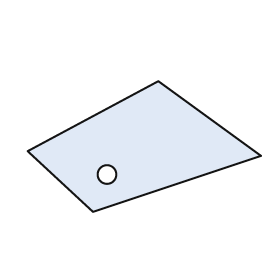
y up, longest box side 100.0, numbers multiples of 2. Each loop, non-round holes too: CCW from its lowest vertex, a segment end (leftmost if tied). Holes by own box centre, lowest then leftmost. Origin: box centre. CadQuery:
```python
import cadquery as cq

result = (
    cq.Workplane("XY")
    .moveTo(-22.0, -28.0)
    .lineTo(50.0, -4.0)
    .lineTo(6.0, 28.0)
    .lineTo(-50.0, -2.0)
    .close()
    .moveTo(-16.0, -12.0)
    .circle(4.0)
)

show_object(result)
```